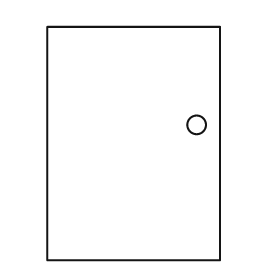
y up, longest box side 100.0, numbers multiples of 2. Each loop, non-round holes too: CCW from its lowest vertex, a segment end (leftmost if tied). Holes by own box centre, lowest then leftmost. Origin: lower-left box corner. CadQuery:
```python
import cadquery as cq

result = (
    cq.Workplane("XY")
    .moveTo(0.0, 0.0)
    .lineTo(74.0, 0.0)
    .lineTo(74.0, 100.0)
    .lineTo(0.0, 100.0)
    .close()
    .moveTo(64.0, 58.0)
    .circle(4.0)
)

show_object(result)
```